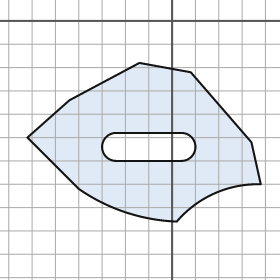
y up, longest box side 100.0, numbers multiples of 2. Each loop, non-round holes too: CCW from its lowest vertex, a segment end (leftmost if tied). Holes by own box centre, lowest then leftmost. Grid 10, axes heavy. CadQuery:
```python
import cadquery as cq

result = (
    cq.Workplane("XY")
    .moveTo(2.0, -86.0)
    .threePointArc((18.0, -74.0), (38.0, -70.0))
    .lineTo(34.0, -52.0)
    .lineTo(8.0, -22.0)
    .lineTo(-14.0, -18.0)
    .lineTo(-44.0, -34.0)
    .lineTo(-62.0, -50.0)
    .lineTo(-40.0, -72.0)
    .threePointArc((-20.0, -82.0), (2.0, -86.0))
    .close()
    .moveTo(-24.0, -60.0)
    .lineTo(4.0, -60.0)
    .threePointArc((10.0, -54.0), (4.0, -48.0))
    .lineTo(-24.0, -48.0)
    .threePointArc((-30.0, -54.0), (-24.0, -60.0))
    .close()
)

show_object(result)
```